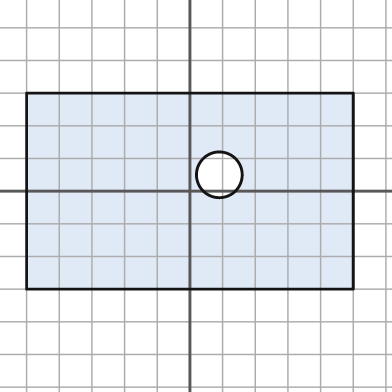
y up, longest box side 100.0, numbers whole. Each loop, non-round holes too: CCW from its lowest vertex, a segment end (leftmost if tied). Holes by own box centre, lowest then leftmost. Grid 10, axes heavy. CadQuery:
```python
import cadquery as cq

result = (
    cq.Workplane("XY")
    .moveTo(-50.0, -30.0)
    .lineTo(50.0, -30.0)
    .lineTo(50.0, 30.0)
    .lineTo(-50.0, 30.0)
    .close()
    .moveTo(9.0, 5.0)
    .circle(7.0)
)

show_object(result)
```